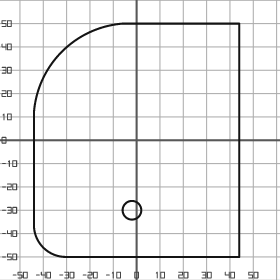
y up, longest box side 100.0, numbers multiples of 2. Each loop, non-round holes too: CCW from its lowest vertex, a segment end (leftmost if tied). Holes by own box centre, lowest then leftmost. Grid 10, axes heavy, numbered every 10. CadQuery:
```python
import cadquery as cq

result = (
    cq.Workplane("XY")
    .moveTo(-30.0, -50.0)
    .lineTo(44.0, -50.0)
    .lineTo(44.0, 50.0)
    .lineTo(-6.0, 50.0)
    .threePointArc((-32.0, 38.0), (-44.0, 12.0))
    .lineTo(-44.0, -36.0)
    .threePointArc((-40.0, -46.0), (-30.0, -50.0))
    .close()
    .moveTo(-2.0, -30.0)
    .circle(4.0)
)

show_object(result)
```